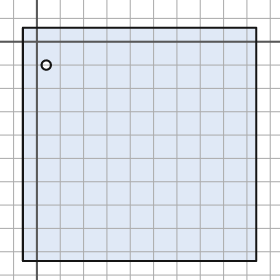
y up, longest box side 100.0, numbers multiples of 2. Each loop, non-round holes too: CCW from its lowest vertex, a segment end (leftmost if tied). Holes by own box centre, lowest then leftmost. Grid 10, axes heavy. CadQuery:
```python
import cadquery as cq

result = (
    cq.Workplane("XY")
    .moveTo(-6.0, -94.0)
    .lineTo(94.0, -94.0)
    .lineTo(94.0, 6.0)
    .lineTo(-6.0, 6.0)
    .close()
    .moveTo(4.0, -10.0)
    .circle(2.0)
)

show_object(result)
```